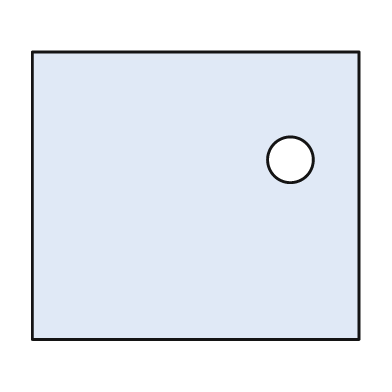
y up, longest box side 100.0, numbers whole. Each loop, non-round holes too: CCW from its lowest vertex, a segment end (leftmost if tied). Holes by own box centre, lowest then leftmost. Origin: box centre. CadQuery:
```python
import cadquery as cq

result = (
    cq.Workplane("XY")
    .moveTo(-50.0, -44.0)
    .lineTo(50.0, -44.0)
    .lineTo(50.0, 44.0)
    .lineTo(-50.0, 44.0)
    .close()
    .moveTo(29.0, 11.0)
    .circle(7.0)
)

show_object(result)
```